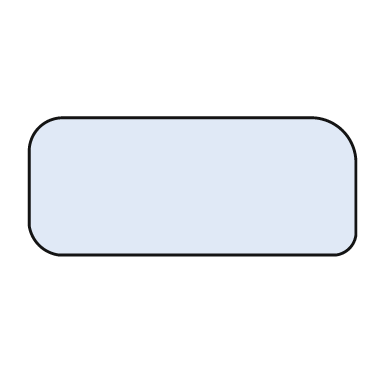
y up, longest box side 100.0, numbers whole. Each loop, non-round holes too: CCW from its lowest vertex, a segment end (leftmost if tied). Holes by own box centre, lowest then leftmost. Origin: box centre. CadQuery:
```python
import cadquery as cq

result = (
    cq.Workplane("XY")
    .moveTo(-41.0, -21.0)
    .lineTo(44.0, -21.0)
    .threePointArc((48.0, -19.0), (50.0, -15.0))
    .lineTo(50.0, 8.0)
    .threePointArc((46.0, 17.0), (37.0, 21.0))
    .lineTo(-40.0, 21.0)
    .threePointArc((-47.0, 18.0), (-50.0, 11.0))
    .lineTo(-50.0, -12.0)
    .threePointArc((-47.0, -18.0), (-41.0, -21.0))
    .close()
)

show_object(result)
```